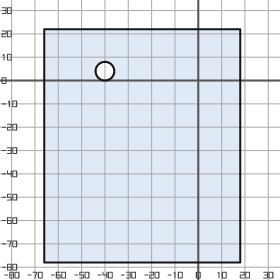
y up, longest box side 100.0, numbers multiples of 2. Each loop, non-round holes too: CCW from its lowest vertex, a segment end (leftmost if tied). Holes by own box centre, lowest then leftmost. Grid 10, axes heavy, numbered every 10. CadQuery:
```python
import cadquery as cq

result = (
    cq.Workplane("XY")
    .moveTo(-66.0, -78.0)
    .lineTo(18.0, -78.0)
    .lineTo(18.0, 22.0)
    .lineTo(-66.0, 22.0)
    .close()
    .moveTo(-40.0, 4.0)
    .circle(4.0)
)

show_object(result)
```